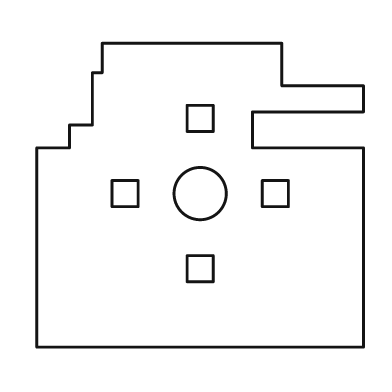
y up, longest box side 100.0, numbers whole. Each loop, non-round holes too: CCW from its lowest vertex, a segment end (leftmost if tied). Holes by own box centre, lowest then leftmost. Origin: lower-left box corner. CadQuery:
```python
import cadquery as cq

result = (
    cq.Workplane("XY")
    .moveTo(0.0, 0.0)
    .lineTo(100.0, 0.0)
    .lineTo(100.0, 61.0)
    .lineTo(66.0, 61.0)
    .lineTo(66.0, 72.0)
    .lineTo(100.0, 72.0)
    .lineTo(100.0, 80.0)
    .lineTo(75.0, 80.0)
    .lineTo(75.0, 93.0)
    .lineTo(20.0, 93.0)
    .lineTo(20.0, 84.0)
    .lineTo(17.0, 84.0)
    .lineTo(17.0, 68.0)
    .lineTo(10.0, 68.0)
    .lineTo(10.0, 61.0)
    .lineTo(0.0, 61.0)
    .close()
    .moveTo(46.0, 20.0)
    .lineTo(54.0, 20.0)
    .lineTo(54.0, 28.0)
    .lineTo(46.0, 28.0)
    .close()
    .moveTo(23.0, 43.0)
    .lineTo(31.0, 43.0)
    .lineTo(31.0, 51.0)
    .lineTo(23.0, 51.0)
    .close()
    .moveTo(50.0, 47.0)
    .circle(8.0)
    .moveTo(69.0, 43.0)
    .lineTo(77.0, 43.0)
    .lineTo(77.0, 51.0)
    .lineTo(69.0, 51.0)
    .close()
    .moveTo(46.0, 66.0)
    .lineTo(54.0, 66.0)
    .lineTo(54.0, 74.0)
    .lineTo(46.0, 74.0)
    .close()
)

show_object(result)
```